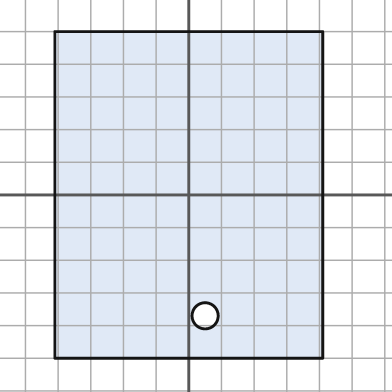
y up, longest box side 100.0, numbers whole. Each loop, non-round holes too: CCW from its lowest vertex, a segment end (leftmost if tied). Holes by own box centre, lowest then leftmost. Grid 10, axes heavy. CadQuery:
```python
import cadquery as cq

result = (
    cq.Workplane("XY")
    .moveTo(-41.0, -50.0)
    .lineTo(41.0, -50.0)
    .lineTo(41.0, 50.0)
    .lineTo(-41.0, 50.0)
    .close()
    .moveTo(5.0, -37.0)
    .circle(4.0)
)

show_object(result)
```